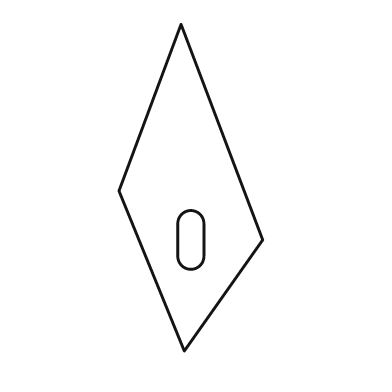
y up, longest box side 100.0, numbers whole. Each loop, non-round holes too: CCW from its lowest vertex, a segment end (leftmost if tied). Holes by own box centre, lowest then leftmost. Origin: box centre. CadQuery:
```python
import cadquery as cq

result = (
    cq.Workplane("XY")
    .moveTo(-2.0, -50.0)
    .lineTo(22.0, -16.0)
    .lineTo(-3.0, 50.0)
    .lineTo(-22.0, -1.0)
    .close()
    .moveTo(-4.0, -21.0)
    .threePointArc((0.0, -25.0), (4.0, -21.0))
    .lineTo(4.0, -11.0)
    .threePointArc((0.0, -7.0), (-4.0, -11.0))
    .close()
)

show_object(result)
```